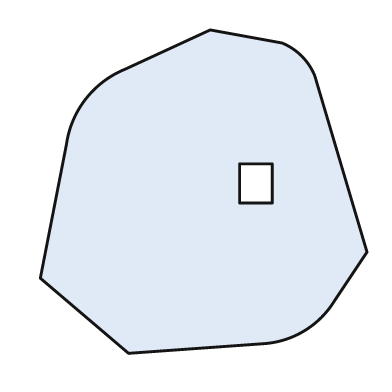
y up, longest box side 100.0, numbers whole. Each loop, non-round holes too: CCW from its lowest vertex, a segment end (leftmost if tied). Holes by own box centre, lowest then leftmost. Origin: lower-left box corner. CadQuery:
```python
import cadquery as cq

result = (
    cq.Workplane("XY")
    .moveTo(27.0, 0.0)
    .lineTo(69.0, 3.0)
    .threePointArc((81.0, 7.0), (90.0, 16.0))
    .lineTo(100.0, 31.0)
    .lineTo(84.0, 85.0)
    .threePointArc((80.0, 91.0), (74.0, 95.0))
    .lineTo(52.0, 99.0)
    .lineTo(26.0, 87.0)
    .threePointArc((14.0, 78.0), (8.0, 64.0))
    .lineTo(0.0, 23.0)
    .close()
    .moveTo(61.0, 46.0)
    .lineTo(71.0, 46.0)
    .lineTo(71.0, 58.0)
    .lineTo(61.0, 58.0)
    .close()
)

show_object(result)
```